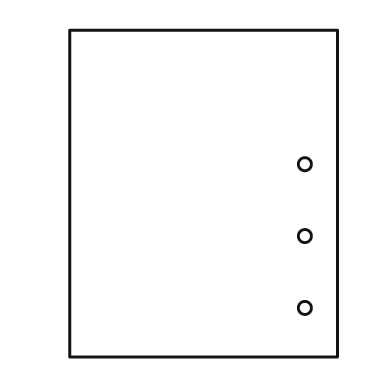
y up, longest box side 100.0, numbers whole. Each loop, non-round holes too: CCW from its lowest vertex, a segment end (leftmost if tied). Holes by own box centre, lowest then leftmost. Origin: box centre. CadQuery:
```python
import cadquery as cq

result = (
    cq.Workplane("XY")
    .moveTo(-41.0, -50.0)
    .lineTo(41.0, -50.0)
    .lineTo(41.0, 50.0)
    .lineTo(-41.0, 50.0)
    .close()
    .moveTo(31.0, -35.0)
    .circle(2.0)
    .moveTo(31.0, -13.0)
    .circle(2.0)
    .moveTo(31.0, 9.0)
    .circle(2.0)
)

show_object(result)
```